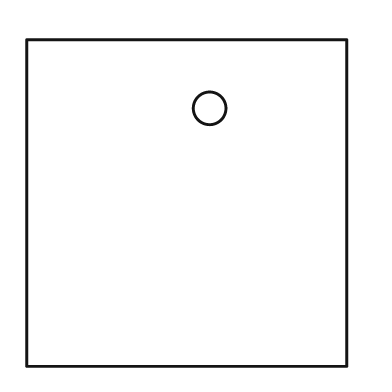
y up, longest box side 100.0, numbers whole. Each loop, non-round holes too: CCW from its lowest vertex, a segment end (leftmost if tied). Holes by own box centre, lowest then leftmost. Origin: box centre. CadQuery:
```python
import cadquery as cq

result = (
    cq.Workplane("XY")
    .moveTo(-49.0, -50.0)
    .lineTo(49.0, -50.0)
    .lineTo(49.0, 50.0)
    .lineTo(-49.0, 50.0)
    .close()
    .moveTo(7.0, 29.0)
    .circle(5.0)
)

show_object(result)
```